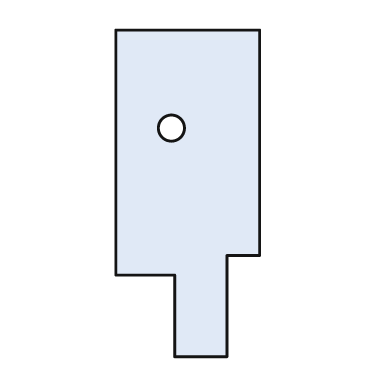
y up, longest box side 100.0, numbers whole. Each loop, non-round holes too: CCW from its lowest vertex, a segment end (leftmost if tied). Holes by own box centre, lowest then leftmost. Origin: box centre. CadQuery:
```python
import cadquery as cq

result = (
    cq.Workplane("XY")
    .moveTo(-4.0, -50.0)
    .lineTo(12.0, -50.0)
    .lineTo(12.0, -19.0)
    .lineTo(22.0, -19.0)
    .lineTo(22.0, 50.0)
    .lineTo(-22.0, 50.0)
    .lineTo(-22.0, -25.0)
    .lineTo(-4.0, -25.0)
    .close()
    .moveTo(-5.0, 20.0)
    .circle(4.0)
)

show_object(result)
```